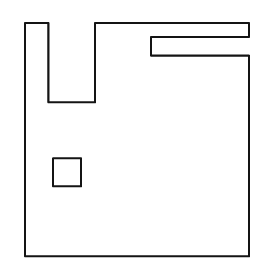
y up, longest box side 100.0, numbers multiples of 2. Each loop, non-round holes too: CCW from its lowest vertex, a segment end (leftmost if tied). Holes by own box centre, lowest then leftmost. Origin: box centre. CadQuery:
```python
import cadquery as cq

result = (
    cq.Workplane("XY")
    .moveTo(-48.0, -50.0)
    .lineTo(48.0, -50.0)
    .lineTo(48.0, 36.0)
    .lineTo(6.0, 36.0)
    .lineTo(6.0, 44.0)
    .lineTo(48.0, 44.0)
    .lineTo(48.0, 50.0)
    .lineTo(-18.0, 50.0)
    .lineTo(-18.0, 16.0)
    .lineTo(-38.0, 16.0)
    .lineTo(-38.0, 50.0)
    .lineTo(-48.0, 50.0)
    .close()
    .moveTo(-36.0, -20.0)
    .lineTo(-24.0, -20.0)
    .lineTo(-24.0, -8.0)
    .lineTo(-36.0, -8.0)
    .close()
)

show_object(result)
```